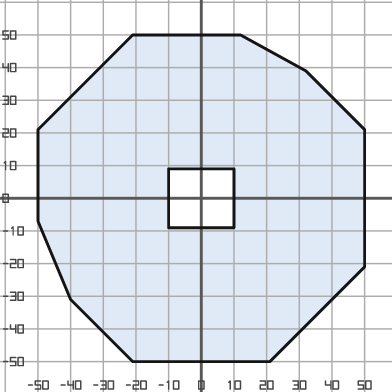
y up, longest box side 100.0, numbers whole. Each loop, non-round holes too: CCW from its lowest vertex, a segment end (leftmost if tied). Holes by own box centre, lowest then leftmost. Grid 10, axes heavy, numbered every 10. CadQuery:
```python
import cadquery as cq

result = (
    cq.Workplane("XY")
    .moveTo(-21.0, -50.0)
    .lineTo(21.0, -50.0)
    .lineTo(50.0, -21.0)
    .lineTo(50.0, 21.0)
    .lineTo(32.0, 39.0)
    .lineTo(12.0, 50.0)
    .lineTo(-21.0, 50.0)
    .lineTo(-50.0, 21.0)
    .lineTo(-50.0, -7.0)
    .lineTo(-40.0, -31.0)
    .close()
    .moveTo(-10.0, -9.0)
    .lineTo(10.0, -9.0)
    .lineTo(10.0, 9.0)
    .lineTo(-10.0, 9.0)
    .close()
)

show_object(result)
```